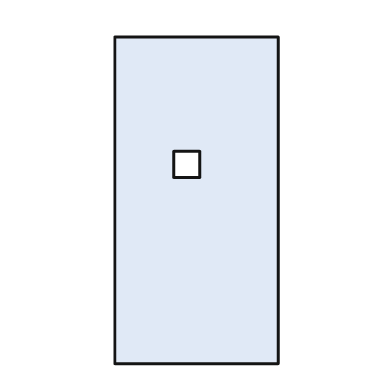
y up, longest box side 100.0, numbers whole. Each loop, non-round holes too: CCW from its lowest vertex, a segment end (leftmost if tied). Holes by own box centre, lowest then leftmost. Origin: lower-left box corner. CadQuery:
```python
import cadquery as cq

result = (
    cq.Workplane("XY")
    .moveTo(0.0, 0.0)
    .lineTo(50.0, 0.0)
    .lineTo(50.0, 100.0)
    .lineTo(0.0, 100.0)
    .close()
    .moveTo(18.0, 57.0)
    .lineTo(26.0, 57.0)
    .lineTo(26.0, 65.0)
    .lineTo(18.0, 65.0)
    .close()
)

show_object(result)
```